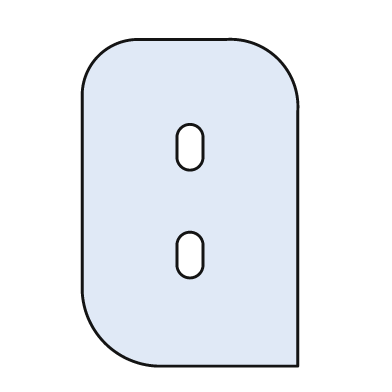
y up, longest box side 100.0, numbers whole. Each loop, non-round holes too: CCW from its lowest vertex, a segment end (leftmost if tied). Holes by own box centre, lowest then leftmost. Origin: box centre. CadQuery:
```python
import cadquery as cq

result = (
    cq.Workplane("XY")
    .moveTo(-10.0, -50.0)
    .lineTo(33.0, -50.0)
    .lineTo(33.0, 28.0)
    .threePointArc((27.0, 44.0), (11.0, 50.0))
    .lineTo(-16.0, 50.0)
    .threePointArc((-28.0, 45.0), (-33.0, 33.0))
    .lineTo(-33.0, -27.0)
    .threePointArc((-26.0, -43.0), (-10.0, -50.0))
    .close()
    .moveTo(-4.0, -19.0)
    .threePointArc((0.0, -23.0), (4.0, -19.0))
    .lineTo(4.0, -13.0)
    .threePointArc((0.0, -9.0), (-4.0, -13.0))
    .close()
    .moveTo(-4.0, 14.0)
    .threePointArc((0.0, 10.0), (4.0, 14.0))
    .lineTo(4.0, 20.0)
    .threePointArc((0.0, 24.0), (-4.0, 20.0))
    .close()
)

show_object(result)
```